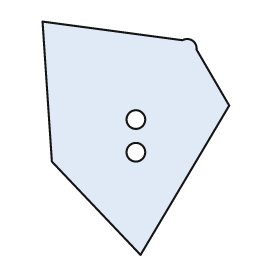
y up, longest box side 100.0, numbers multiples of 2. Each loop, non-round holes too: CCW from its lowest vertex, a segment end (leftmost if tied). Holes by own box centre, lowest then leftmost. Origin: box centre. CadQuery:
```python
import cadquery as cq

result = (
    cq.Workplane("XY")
    .moveTo(2.0, -50.0)
    .lineTo(40.0, 14.0)
    .lineTo(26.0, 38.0)
    .threePointArc((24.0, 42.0), (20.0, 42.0))
    .lineTo(-40.0, 50.0)
    .lineTo(-36.0, -10.0)
    .close()
    .moveTo(0.0, -6.0)
    .circle(4.0)
    .moveTo(0.0, 8.0)
    .circle(4.0)
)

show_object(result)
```